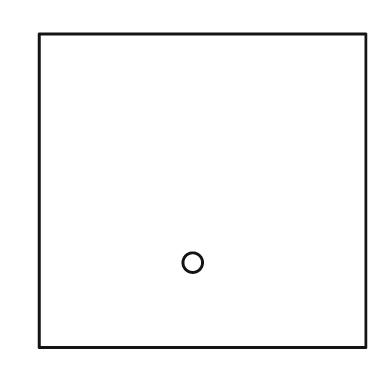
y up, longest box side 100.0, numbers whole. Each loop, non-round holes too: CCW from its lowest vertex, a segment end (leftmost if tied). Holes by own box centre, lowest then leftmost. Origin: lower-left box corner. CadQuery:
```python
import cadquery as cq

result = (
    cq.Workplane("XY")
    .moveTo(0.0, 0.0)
    .lineTo(100.0, 0.0)
    .lineTo(100.0, 96.0)
    .lineTo(0.0, 96.0)
    .close()
    .moveTo(47.0, 26.0)
    .circle(3.0)
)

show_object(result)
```